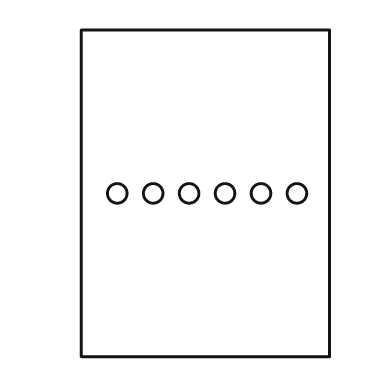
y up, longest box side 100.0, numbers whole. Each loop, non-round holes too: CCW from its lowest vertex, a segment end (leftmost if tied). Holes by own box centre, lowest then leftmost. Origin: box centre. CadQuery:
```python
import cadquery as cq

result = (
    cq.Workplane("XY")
    .moveTo(-38.0, -50.0)
    .lineTo(38.0, -50.0)
    .lineTo(38.0, 50.0)
    .lineTo(-38.0, 50.0)
    .close()
    .moveTo(-27.0, 0.0)
    .circle(3.0)
    .moveTo(-16.0, 0.0)
    .circle(3.0)
    .moveTo(-5.0, 0.0)
    .circle(3.0)
    .moveTo(6.0, 0.0)
    .circle(3.0)
    .moveTo(17.0, 0.0)
    .circle(3.0)
    .moveTo(28.0, 0.0)
    .circle(3.0)
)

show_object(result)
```